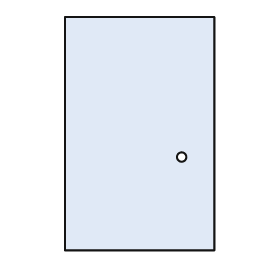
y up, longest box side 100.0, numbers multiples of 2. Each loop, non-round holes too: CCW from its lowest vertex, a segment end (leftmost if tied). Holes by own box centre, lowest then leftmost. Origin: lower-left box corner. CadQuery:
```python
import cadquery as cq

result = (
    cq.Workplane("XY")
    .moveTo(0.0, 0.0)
    .lineTo(64.0, 0.0)
    .lineTo(64.0, 100.0)
    .lineTo(0.0, 100.0)
    .close()
    .moveTo(50.0, 40.0)
    .circle(2.0)
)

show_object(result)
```